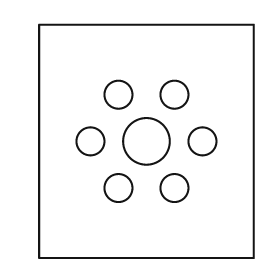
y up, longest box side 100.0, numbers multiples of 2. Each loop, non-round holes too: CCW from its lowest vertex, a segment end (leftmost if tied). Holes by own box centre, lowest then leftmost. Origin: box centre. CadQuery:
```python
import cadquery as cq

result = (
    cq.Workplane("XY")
    .moveTo(-46.0, -50.0)
    .lineTo(46.0, -50.0)
    .lineTo(46.0, 50.0)
    .lineTo(-46.0, 50.0)
    .close()
    .moveTo(-12.0, -20.0)
    .circle(6.0)
    .moveTo(12.0, -20.0)
    .circle(6.0)
    .moveTo(-24.0, 0.0)
    .circle(6.0)
    .moveTo(0.0, 0.0)
    .circle(10.0)
    .moveTo(24.0, 0.0)
    .circle(6.0)
    .moveTo(-12.0, 20.0)
    .circle(6.0)
    .moveTo(12.0, 20.0)
    .circle(6.0)
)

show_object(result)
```